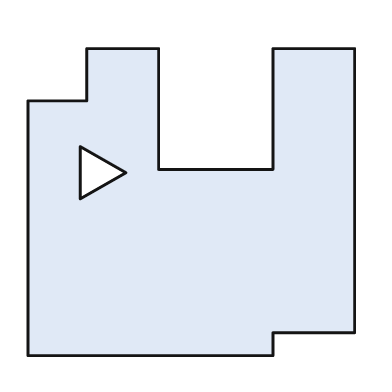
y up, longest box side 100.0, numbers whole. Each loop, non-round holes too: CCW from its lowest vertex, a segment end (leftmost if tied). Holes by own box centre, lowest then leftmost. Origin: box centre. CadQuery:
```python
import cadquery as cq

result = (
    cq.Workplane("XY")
    .moveTo(-50.0, -47.0)
    .lineTo(25.0, -47.0)
    .lineTo(25.0, -40.0)
    .lineTo(50.0, -40.0)
    .lineTo(50.0, 47.0)
    .lineTo(25.0, 47.0)
    .lineTo(25.0, 10.0)
    .lineTo(-10.0, 10.0)
    .lineTo(-10.0, 47.0)
    .lineTo(-32.0, 47.0)
    .lineTo(-32.0, 31.0)
    .lineTo(-50.0, 31.0)
    .close()
    .moveTo(-34.0, 1.0)
    .lineTo(-20.0, 9.0)
    .lineTo(-34.0, 17.0)
    .close()
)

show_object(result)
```